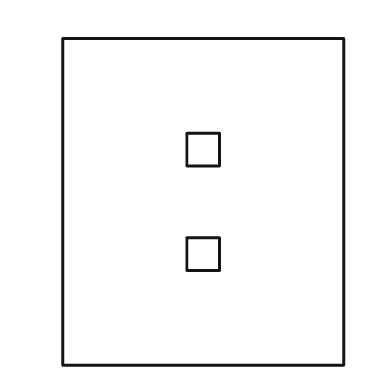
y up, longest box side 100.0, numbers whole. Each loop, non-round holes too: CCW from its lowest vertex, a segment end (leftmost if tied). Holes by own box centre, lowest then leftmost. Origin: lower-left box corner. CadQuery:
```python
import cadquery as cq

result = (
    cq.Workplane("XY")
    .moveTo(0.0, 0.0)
    .lineTo(86.0, 0.0)
    .lineTo(86.0, 100.0)
    .lineTo(0.0, 100.0)
    .close()
    .moveTo(38.0, 29.0)
    .lineTo(48.0, 29.0)
    .lineTo(48.0, 39.0)
    .lineTo(38.0, 39.0)
    .close()
    .moveTo(38.0, 61.0)
    .lineTo(48.0, 61.0)
    .lineTo(48.0, 71.0)
    .lineTo(38.0, 71.0)
    .close()
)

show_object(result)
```